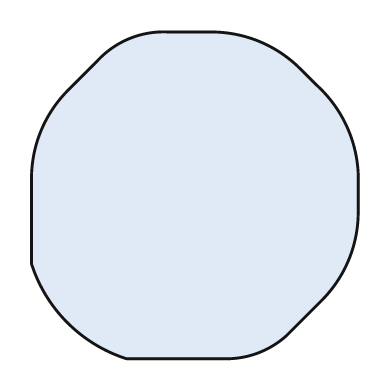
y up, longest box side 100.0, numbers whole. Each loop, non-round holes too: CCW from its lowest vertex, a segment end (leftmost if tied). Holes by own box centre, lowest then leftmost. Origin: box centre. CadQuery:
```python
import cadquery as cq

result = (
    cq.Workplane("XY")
    .moveTo(-21.0, -50.0)
    .lineTo(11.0, -50.0)
    .threePointArc((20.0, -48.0), (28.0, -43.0))
    .lineTo(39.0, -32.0)
    .threePointArc((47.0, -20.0), (50.0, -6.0))
    .lineTo(50.0, 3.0)
    .threePointArc((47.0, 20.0), (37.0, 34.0))
    .lineTo(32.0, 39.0)
    .threePointArc((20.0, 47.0), (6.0, 50.0))
    .lineTo(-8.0, 50.0)
    .threePointArc((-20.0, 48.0), (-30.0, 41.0))
    .lineTo(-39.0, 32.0)
    .threePointArc((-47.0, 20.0), (-50.0, 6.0))
    .lineTo(-50.0, -21.0)
    .threePointArc((-39.0, -39.0), (-21.0, -50.0))
    .close()
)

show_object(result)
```